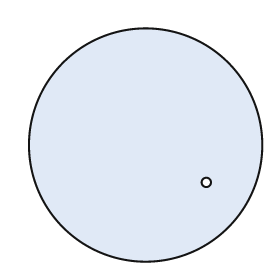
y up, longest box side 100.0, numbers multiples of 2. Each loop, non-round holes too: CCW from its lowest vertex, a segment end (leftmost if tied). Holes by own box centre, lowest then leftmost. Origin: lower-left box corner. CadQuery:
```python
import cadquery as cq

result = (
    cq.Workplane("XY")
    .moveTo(50.0, 50.0)
    .circle(50.0)
    .moveTo(76.0, 34.0)
    .circle(2.0)
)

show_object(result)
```